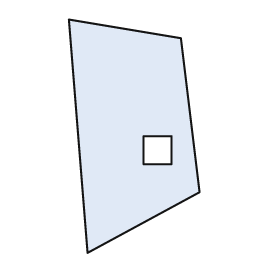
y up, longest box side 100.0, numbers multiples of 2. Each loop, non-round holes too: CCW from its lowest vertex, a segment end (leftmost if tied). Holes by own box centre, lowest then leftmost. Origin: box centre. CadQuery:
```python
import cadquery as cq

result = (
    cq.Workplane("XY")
    .moveTo(-20.0, -50.0)
    .lineTo(28.0, -24.0)
    .lineTo(20.0, 42.0)
    .lineTo(-28.0, 50.0)
    .close()
    .moveTo(4.0, -12.0)
    .lineTo(16.0, -12.0)
    .lineTo(16.0, 0.0)
    .lineTo(4.0, 0.0)
    .close()
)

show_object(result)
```